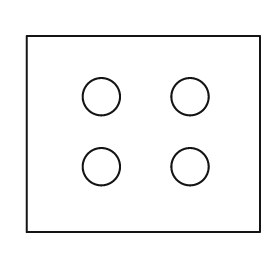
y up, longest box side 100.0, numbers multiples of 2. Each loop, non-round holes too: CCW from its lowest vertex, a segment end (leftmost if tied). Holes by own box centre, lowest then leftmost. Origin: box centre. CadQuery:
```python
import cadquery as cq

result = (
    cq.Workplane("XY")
    .moveTo(-50.0, -42.0)
    .lineTo(50.0, -42.0)
    .lineTo(50.0, 42.0)
    .lineTo(-50.0, 42.0)
    .close()
    .moveTo(-18.0, -14.0)
    .circle(8.0)
    .moveTo(20.0, -14.0)
    .circle(8.0)
    .moveTo(-18.0, 16.0)
    .circle(8.0)
    .moveTo(20.0, 16.0)
    .circle(8.0)
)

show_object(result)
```